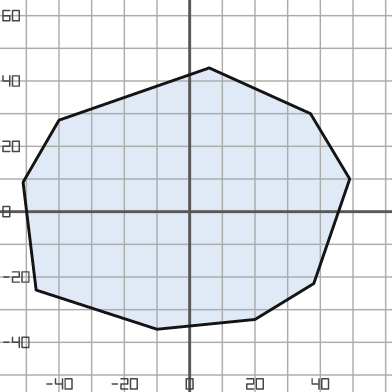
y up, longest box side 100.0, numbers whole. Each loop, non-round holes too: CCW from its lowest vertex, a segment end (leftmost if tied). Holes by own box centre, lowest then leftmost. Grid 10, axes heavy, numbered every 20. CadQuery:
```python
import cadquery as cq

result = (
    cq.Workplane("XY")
    .moveTo(-10.0, -36.0)
    .lineTo(20.0, -33.0)
    .lineTo(38.0, -22.0)
    .lineTo(49.0, 10.0)
    .lineTo(37.0, 30.0)
    .lineTo(6.0, 44.0)
    .lineTo(-40.0, 28.0)
    .lineTo(-51.0, 9.0)
    .lineTo(-47.0, -24.0)
    .close()
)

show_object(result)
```